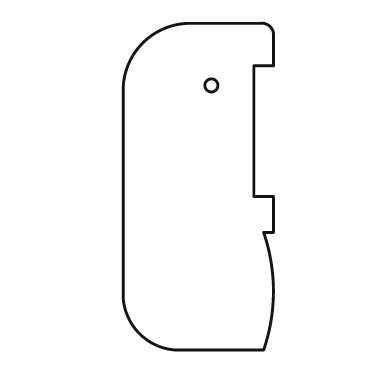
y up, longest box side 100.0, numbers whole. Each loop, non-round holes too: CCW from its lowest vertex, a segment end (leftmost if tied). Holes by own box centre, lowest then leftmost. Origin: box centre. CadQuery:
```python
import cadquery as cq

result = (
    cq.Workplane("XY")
    .moveTo(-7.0, -50.0)
    .lineTo(20.0, -50.0)
    .threePointArc((23.0, -32.0), (20.0, -14.0))
    .lineTo(23.0, -14.0)
    .lineTo(23.0, -3.0)
    .lineTo(17.0, -3.0)
    .lineTo(17.0, 37.0)
    .lineTo(23.0, 37.0)
    .lineTo(23.0, 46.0)
    .threePointArc((22.0, 49.0), (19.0, 50.0))
    .lineTo(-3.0, 50.0)
    .threePointArc((-17.0, 44.0), (-23.0, 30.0))
    .lineTo(-23.0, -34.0)
    .threePointArc((-18.0, -45.0), (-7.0, -50.0))
    .close()
    .moveTo(4.0, 31.0)
    .circle(2.0)
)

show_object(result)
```